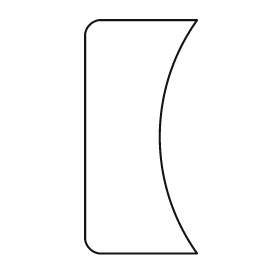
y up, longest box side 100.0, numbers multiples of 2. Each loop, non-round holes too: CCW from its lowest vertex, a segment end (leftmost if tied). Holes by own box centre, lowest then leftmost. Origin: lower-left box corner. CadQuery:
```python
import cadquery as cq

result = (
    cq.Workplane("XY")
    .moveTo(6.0, 0.0)
    .lineTo(48.0, 0.0)
    .threePointArc((32.0, 50.0), (48.0, 100.0))
    .lineTo(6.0, 100.0)
    .threePointArc((2.0, 98.0), (0.0, 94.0))
    .lineTo(0.0, 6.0)
    .threePointArc((2.0, 2.0), (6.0, 0.0))
    .close()
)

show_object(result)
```